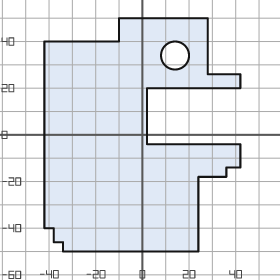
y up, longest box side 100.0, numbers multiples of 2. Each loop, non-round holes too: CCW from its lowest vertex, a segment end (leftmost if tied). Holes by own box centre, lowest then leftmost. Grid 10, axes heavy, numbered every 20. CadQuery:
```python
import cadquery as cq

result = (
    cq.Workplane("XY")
    .moveTo(-34.0, -50.0)
    .lineTo(24.0, -50.0)
    .lineTo(24.0, -18.0)
    .lineTo(36.0, -18.0)
    .lineTo(36.0, -14.0)
    .lineTo(42.0, -14.0)
    .lineTo(42.0, -4.0)
    .lineTo(2.0, -4.0)
    .lineTo(2.0, 20.0)
    .lineTo(42.0, 20.0)
    .lineTo(42.0, 26.0)
    .lineTo(28.0, 26.0)
    .lineTo(28.0, 50.0)
    .lineTo(-10.0, 50.0)
    .lineTo(-10.0, 40.0)
    .lineTo(-42.0, 40.0)
    .lineTo(-42.0, -40.0)
    .lineTo(-38.0, -40.0)
    .lineTo(-38.0, -46.0)
    .lineTo(-34.0, -46.0)
    .close()
    .moveTo(14.0, 34.0)
    .circle(6.0)
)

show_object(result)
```